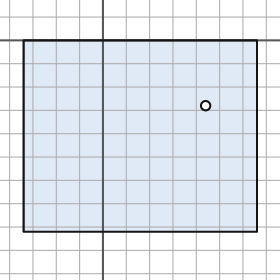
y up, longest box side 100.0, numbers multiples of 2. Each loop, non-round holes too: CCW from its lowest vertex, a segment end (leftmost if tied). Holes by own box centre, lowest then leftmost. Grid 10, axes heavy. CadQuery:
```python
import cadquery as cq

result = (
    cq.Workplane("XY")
    .moveTo(-34.0, -82.0)
    .lineTo(66.0, -82.0)
    .lineTo(66.0, 0.0)
    .lineTo(-34.0, 0.0)
    .close()
    .moveTo(44.0, -28.0)
    .circle(2.0)
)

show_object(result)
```